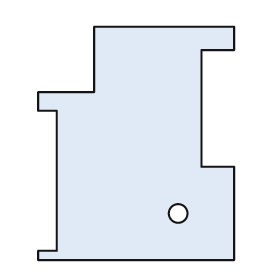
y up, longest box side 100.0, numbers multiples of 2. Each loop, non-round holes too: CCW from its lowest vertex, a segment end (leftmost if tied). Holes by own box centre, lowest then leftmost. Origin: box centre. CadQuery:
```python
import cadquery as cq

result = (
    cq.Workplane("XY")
    .moveTo(-42.0, -50.0)
    .lineTo(42.0, -50.0)
    .lineTo(42.0, -10.0)
    .lineTo(28.0, -10.0)
    .lineTo(28.0, 40.0)
    .lineTo(42.0, 40.0)
    .lineTo(42.0, 50.0)
    .lineTo(-18.0, 50.0)
    .lineTo(-18.0, 22.0)
    .lineTo(-42.0, 22.0)
    .lineTo(-42.0, 14.0)
    .lineTo(-34.0, 14.0)
    .lineTo(-34.0, -46.0)
    .lineTo(-42.0, -46.0)
    .close()
    .moveTo(18.0, -30.0)
    .circle(4.0)
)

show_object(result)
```